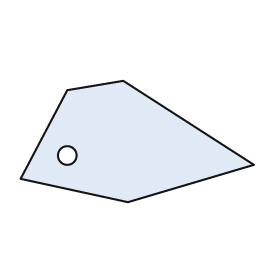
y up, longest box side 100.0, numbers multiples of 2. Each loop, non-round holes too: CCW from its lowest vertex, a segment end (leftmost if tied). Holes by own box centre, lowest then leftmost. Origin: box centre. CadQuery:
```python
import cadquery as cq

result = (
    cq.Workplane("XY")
    .moveTo(-4.0, -26.0)
    .lineTo(50.0, -10.0)
    .lineTo(-6.0, 26.0)
    .lineTo(-30.0, 22.0)
    .lineTo(-50.0, -16.0)
    .close()
    .moveTo(-30.0, -6.0)
    .circle(4.0)
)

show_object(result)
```